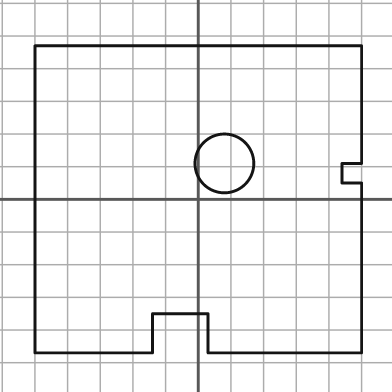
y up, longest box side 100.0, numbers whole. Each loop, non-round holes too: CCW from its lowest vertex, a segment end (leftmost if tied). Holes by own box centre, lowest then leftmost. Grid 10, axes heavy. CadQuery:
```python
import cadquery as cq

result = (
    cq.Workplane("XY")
    .moveTo(-50.0, -47.0)
    .lineTo(-14.0, -47.0)
    .lineTo(-14.0, -35.0)
    .lineTo(3.0, -35.0)
    .lineTo(3.0, -47.0)
    .lineTo(50.0, -47.0)
    .lineTo(50.0, 5.0)
    .lineTo(44.0, 5.0)
    .lineTo(44.0, 11.0)
    .lineTo(50.0, 11.0)
    .lineTo(50.0, 47.0)
    .lineTo(-50.0, 47.0)
    .close()
    .moveTo(8.0, 11.0)
    .circle(9.0)
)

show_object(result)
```